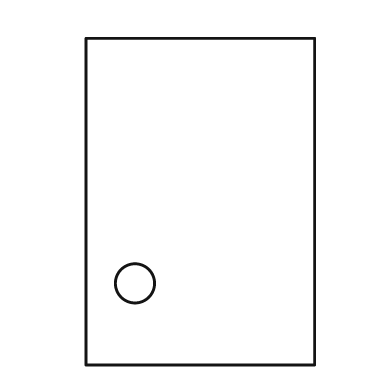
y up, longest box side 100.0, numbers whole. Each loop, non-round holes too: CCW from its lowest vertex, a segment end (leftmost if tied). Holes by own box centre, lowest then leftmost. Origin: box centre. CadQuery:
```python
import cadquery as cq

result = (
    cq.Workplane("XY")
    .moveTo(-35.0, -50.0)
    .lineTo(35.0, -50.0)
    .lineTo(35.0, 50.0)
    .lineTo(-35.0, 50.0)
    .close()
    .moveTo(-20.0, -25.0)
    .circle(6.0)
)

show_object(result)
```